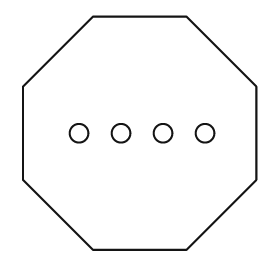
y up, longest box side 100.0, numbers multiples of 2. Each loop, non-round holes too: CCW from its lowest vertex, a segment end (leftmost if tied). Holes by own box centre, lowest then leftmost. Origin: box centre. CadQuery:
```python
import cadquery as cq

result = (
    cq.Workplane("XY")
    .moveTo(-20.0, -50.0)
    .lineTo(20.0, -50.0)
    .lineTo(50.0, -20.0)
    .lineTo(50.0, 20.0)
    .lineTo(20.0, 50.0)
    .lineTo(-20.0, 50.0)
    .lineTo(-50.0, 20.0)
    .lineTo(-50.0, -20.0)
    .close()
    .moveTo(-26.0, 0.0)
    .circle(4.0)
    .moveTo(-8.0, 0.0)
    .circle(4.0)
    .moveTo(10.0, 0.0)
    .circle(4.0)
    .moveTo(28.0, 0.0)
    .circle(4.0)
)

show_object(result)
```